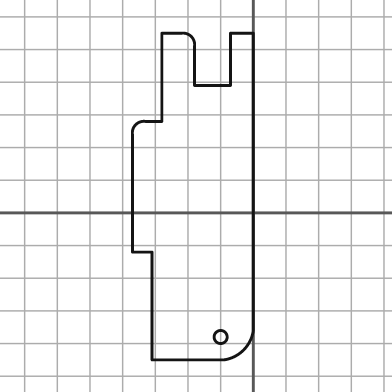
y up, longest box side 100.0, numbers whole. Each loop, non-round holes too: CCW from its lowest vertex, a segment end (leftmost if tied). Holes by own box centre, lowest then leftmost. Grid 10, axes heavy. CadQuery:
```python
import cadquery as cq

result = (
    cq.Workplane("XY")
    .moveTo(-31.0, -45.0)
    .lineTo(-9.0, -45.0)
    .threePointArc((-3.0, -42.0), (0.0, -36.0))
    .lineTo(0.0, 55.0)
    .lineTo(-7.0, 55.0)
    .lineTo(-7.0, 39.0)
    .lineTo(-18.0, 39.0)
    .lineTo(-18.0, 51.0)
    .threePointArc((-19.0, 54.0), (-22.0, 55.0))
    .lineTo(-28.0, 55.0)
    .lineTo(-28.0, 28.0)
    .lineTo(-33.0, 28.0)
    .threePointArc((-36.0, 27.0), (-37.0, 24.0))
    .lineTo(-37.0, -12.0)
    .lineTo(-31.0, -12.0)
    .close()
    .moveTo(-10.0, -38.0)
    .circle(2.0)
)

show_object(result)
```